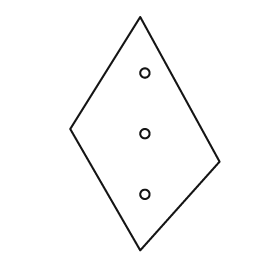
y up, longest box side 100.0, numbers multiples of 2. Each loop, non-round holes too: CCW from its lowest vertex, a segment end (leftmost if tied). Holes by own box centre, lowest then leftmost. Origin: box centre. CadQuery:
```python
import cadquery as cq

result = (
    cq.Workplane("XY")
    .moveTo(-2.0, -50.0)
    .lineTo(32.0, -12.0)
    .lineTo(-2.0, 50.0)
    .lineTo(-32.0, 2.0)
    .close()
    .moveTo(0.0, -26.0)
    .circle(2.0)
    .moveTo(0.0, 0.0)
    .circle(2.0)
    .moveTo(0.0, 26.0)
    .circle(2.0)
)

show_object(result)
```